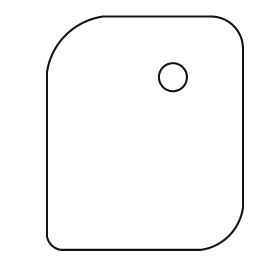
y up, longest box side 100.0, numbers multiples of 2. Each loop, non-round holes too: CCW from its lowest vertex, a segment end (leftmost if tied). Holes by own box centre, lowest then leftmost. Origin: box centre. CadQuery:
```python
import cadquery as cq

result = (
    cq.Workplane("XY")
    .moveTo(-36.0, -50.0)
    .lineTo(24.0, -50.0)
    .threePointArc((36.0, -44.0), (42.0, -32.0))
    .lineTo(42.0, 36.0)
    .threePointArc((38.0, 46.0), (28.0, 50.0))
    .lineTo(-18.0, 50.0)
    .threePointArc((-34.0, 42.0), (-42.0, 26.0))
    .lineTo(-42.0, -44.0)
    .threePointArc((-40.0, -48.0), (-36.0, -50.0))
    .close()
    .moveTo(12.0, 24.0)
    .circle(6.0)
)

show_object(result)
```